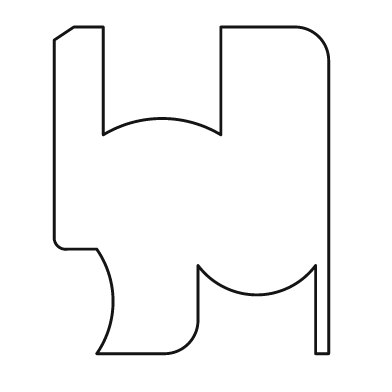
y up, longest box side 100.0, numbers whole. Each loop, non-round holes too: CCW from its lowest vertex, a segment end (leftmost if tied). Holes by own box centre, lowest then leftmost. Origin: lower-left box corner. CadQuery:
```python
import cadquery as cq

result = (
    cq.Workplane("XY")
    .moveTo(13.0, 0.0)
    .lineTo(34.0, 0.0)
    .threePointArc((41.0, 3.0), (44.0, 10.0))
    .lineTo(44.0, 27.0)
    .threePointArc((62.0, 18.0), (80.0, 27.0))
    .lineTo(80.0, 0.0)
    .lineTo(84.0, 0.0)
    .lineTo(84.0, 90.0)
    .threePointArc((81.0, 97.0), (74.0, 100.0))
    .lineTo(51.0, 100.0)
    .lineTo(51.0, 67.0)
    .threePointArc((33.0, 72.0), (15.0, 67.0))
    .lineTo(15.0, 100.0)
    .lineTo(6.0, 100.0)
    .lineTo(0.0, 96.0)
    .lineTo(0.0, 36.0)
    .threePointArc((1.0, 33.0), (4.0, 32.0))
    .lineTo(13.0, 32.0)
    .threePointArc((18.0, 16.0), (13.0, 0.0))
    .close()
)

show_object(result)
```